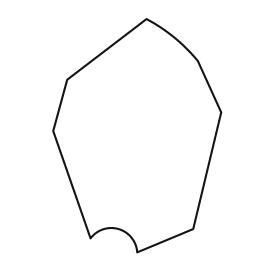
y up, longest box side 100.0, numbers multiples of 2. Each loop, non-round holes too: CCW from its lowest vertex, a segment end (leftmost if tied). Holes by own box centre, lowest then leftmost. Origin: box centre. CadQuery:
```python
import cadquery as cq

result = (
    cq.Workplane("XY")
    .moveTo(0.0, -50.0)
    .lineTo(24.0, -40.0)
    .lineTo(36.0, 10.0)
    .lineTo(26.0, 32.0)
    .threePointArc((16.0, 42.0), (4.0, 50.0))
    .lineTo(-30.0, 24.0)
    .lineTo(-36.0, 2.0)
    .lineTo(-20.0, -44.0)
    .threePointArc((-8.0, -40.0), (0.0, -50.0))
    .close()
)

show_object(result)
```